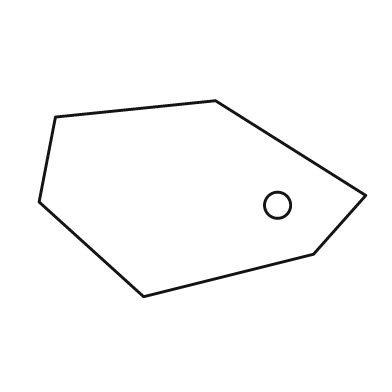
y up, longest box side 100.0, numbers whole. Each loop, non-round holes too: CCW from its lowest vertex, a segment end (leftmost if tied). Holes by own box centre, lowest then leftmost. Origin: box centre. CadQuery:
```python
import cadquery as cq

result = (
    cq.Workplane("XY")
    .moveTo(-18.0, -30.0)
    .lineTo(34.0, -17.0)
    .lineTo(50.0, 1.0)
    .lineTo(4.0, 30.0)
    .lineTo(-45.0, 25.0)
    .lineTo(-50.0, -1.0)
    .close()
    .moveTo(23.0, -2.0)
    .circle(4.0)
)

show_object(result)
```